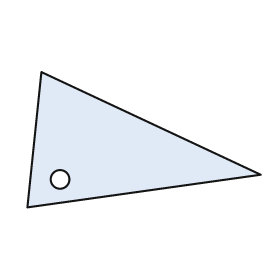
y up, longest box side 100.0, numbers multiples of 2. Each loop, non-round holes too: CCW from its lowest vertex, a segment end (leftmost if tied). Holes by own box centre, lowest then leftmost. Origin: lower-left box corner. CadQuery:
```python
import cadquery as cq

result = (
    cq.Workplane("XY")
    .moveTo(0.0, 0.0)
    .lineTo(100.0, 14.0)
    .lineTo(6.0, 58.0)
    .close()
    .moveTo(14.0, 12.0)
    .circle(4.0)
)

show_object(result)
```